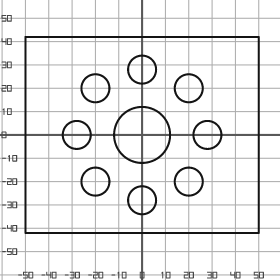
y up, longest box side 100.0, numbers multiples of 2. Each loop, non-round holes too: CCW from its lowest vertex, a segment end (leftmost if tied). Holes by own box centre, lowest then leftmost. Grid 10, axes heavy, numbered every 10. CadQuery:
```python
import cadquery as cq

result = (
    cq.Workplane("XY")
    .moveTo(-50.0, -42.0)
    .lineTo(50.0, -42.0)
    .lineTo(50.0, 42.0)
    .lineTo(-50.0, 42.0)
    .close()
    .moveTo(0.0, -28.0)
    .circle(6.0)
    .moveTo(-20.0, -20.0)
    .circle(6.0)
    .moveTo(20.0, -20.0)
    .circle(6.0)
    .moveTo(-28.0, 0.0)
    .circle(6.0)
    .moveTo(0.0, 0.0)
    .circle(12.0)
    .moveTo(28.0, 0.0)
    .circle(6.0)
    .moveTo(-20.0, 20.0)
    .circle(6.0)
    .moveTo(20.0, 20.0)
    .circle(6.0)
    .moveTo(0.0, 28.0)
    .circle(6.0)
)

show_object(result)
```